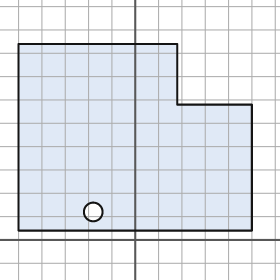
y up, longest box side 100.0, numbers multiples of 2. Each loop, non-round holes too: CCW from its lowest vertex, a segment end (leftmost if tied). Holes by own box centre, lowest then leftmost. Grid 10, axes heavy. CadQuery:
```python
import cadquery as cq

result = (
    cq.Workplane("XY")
    .moveTo(-50.0, 4.0)
    .lineTo(50.0, 4.0)
    .lineTo(50.0, 58.0)
    .lineTo(18.0, 58.0)
    .lineTo(18.0, 84.0)
    .lineTo(-50.0, 84.0)
    .close()
    .moveTo(-18.0, 12.0)
    .circle(4.0)
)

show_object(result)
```